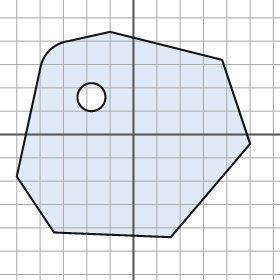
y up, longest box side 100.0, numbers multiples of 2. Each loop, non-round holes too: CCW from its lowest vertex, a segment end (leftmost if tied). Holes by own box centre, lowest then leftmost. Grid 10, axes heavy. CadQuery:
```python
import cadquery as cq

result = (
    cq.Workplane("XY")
    .moveTo(16.0, -44.0)
    .lineTo(50.0, -4.0)
    .lineTo(38.0, 32.0)
    .lineTo(-10.0, 44.0)
    .lineTo(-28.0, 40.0)
    .threePointArc((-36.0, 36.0), (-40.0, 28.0))
    .lineTo(-50.0, -18.0)
    .lineTo(-34.0, -42.0)
    .close()
    .moveTo(-18.0, 16.0)
    .circle(6.0)
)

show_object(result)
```